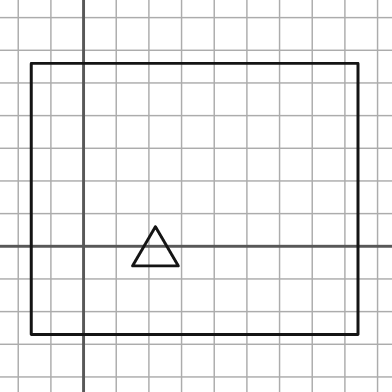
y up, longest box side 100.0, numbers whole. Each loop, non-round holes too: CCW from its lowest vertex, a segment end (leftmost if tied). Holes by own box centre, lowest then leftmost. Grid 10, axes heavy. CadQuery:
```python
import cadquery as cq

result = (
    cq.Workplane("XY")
    .moveTo(-16.0, -27.0)
    .lineTo(84.0, -27.0)
    .lineTo(84.0, 56.0)
    .lineTo(-16.0, 56.0)
    .close()
    .moveTo(15.0, -6.0)
    .lineTo(29.0, -6.0)
    .lineTo(22.0, 6.0)
    .close()
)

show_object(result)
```